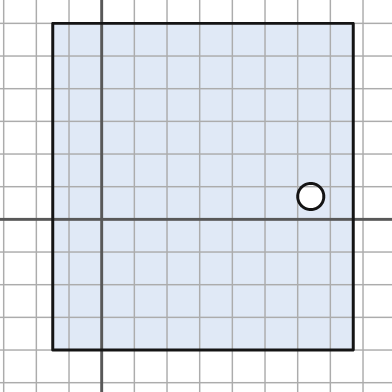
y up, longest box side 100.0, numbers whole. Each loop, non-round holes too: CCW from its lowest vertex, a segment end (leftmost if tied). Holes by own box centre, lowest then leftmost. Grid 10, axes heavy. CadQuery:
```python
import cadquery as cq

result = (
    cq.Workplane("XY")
    .moveTo(-15.0, -40.0)
    .lineTo(77.0, -40.0)
    .lineTo(77.0, 60.0)
    .lineTo(-15.0, 60.0)
    .close()
    .moveTo(64.0, 7.0)
    .circle(4.0)
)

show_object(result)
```